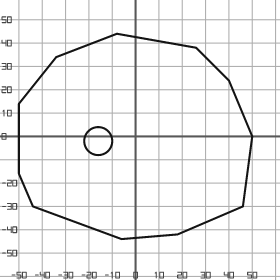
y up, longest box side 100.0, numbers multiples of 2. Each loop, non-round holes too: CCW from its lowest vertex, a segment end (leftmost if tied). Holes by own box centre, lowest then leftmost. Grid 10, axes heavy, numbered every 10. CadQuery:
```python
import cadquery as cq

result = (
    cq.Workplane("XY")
    .moveTo(-6.0, -44.0)
    .lineTo(18.0, -42.0)
    .lineTo(46.0, -30.0)
    .lineTo(50.0, 0.0)
    .lineTo(40.0, 24.0)
    .lineTo(26.0, 38.0)
    .lineTo(-8.0, 44.0)
    .lineTo(-34.0, 34.0)
    .lineTo(-50.0, 14.0)
    .lineTo(-50.0, -16.0)
    .lineTo(-44.0, -30.0)
    .close()
    .moveTo(-16.0, -2.0)
    .circle(6.0)
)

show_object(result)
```